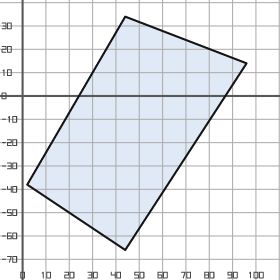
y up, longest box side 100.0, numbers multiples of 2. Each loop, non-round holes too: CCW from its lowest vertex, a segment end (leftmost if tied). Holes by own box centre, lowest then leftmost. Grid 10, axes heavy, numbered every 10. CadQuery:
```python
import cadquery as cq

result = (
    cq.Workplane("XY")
    .moveTo(44.0, -66.0)
    .lineTo(96.0, 14.0)
    .lineTo(44.0, 34.0)
    .lineTo(2.0, -38.0)
    .close()
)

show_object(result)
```